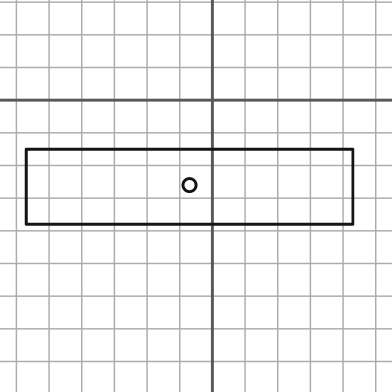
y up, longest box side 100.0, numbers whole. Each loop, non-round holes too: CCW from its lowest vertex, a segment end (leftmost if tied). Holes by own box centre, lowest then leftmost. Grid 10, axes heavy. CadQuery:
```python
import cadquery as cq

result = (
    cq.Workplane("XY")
    .moveTo(-57.0, -38.0)
    .lineTo(43.0, -38.0)
    .lineTo(43.0, -15.0)
    .lineTo(-57.0, -15.0)
    .close()
    .moveTo(-7.0, -26.0)
    .circle(2.0)
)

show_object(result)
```